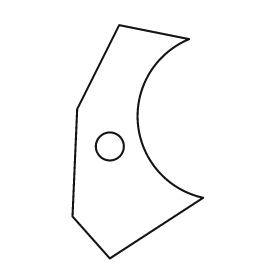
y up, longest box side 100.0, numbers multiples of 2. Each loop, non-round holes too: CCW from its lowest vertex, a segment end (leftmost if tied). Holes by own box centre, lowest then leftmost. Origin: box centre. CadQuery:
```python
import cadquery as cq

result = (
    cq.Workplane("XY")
    .moveTo(-12.0, -50.0)
    .lineTo(28.0, -24.0)
    .threePointArc((0.0, 8.0), (22.0, 44.0))
    .lineTo(-8.0, 50.0)
    .lineTo(-26.0, 14.0)
    .lineTo(-28.0, -32.0)
    .close()
    .moveTo(-12.0, -2.0)
    .circle(6.0)
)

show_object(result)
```